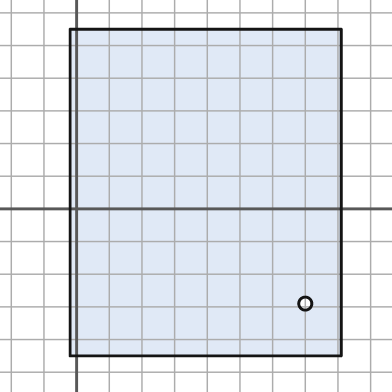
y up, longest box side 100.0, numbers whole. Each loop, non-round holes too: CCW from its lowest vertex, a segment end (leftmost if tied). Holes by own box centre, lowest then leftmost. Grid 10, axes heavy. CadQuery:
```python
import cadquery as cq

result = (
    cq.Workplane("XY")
    .moveTo(-2.0, -45.0)
    .lineTo(81.0, -45.0)
    .lineTo(81.0, 55.0)
    .lineTo(-2.0, 55.0)
    .close()
    .moveTo(70.0, -29.0)
    .circle(2.0)
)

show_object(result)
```